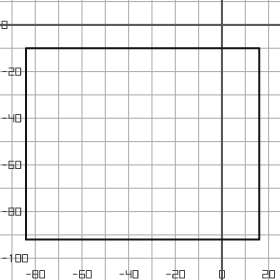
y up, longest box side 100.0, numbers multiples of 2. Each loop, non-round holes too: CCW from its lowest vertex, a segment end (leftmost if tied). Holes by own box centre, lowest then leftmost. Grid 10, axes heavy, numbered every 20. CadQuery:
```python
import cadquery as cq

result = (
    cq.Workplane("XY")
    .moveTo(-84.0, -92.0)
    .lineTo(16.0, -92.0)
    .lineTo(16.0, -10.0)
    .lineTo(-84.0, -10.0)
    .close()
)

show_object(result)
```